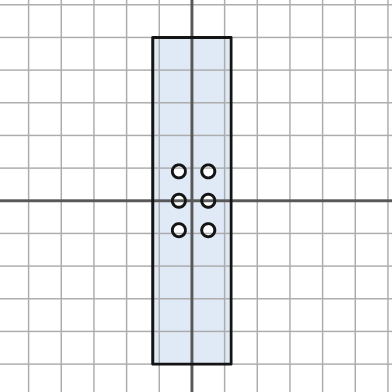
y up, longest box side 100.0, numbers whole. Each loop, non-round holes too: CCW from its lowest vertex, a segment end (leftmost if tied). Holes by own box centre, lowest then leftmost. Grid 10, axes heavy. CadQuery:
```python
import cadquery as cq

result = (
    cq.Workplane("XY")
    .moveTo(-12.0, -50.0)
    .lineTo(12.0, -50.0)
    .lineTo(12.0, 50.0)
    .lineTo(-12.0, 50.0)
    .close()
    .moveTo(-4.0, -9.0)
    .circle(2.0)
    .moveTo(5.0, -9.0)
    .circle(2.0)
    .moveTo(-4.0, 0.0)
    .circle(2.0)
    .moveTo(5.0, 0.0)
    .circle(2.0)
    .moveTo(-4.0, 9.0)
    .circle(2.0)
    .moveTo(5.0, 9.0)
    .circle(2.0)
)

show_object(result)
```